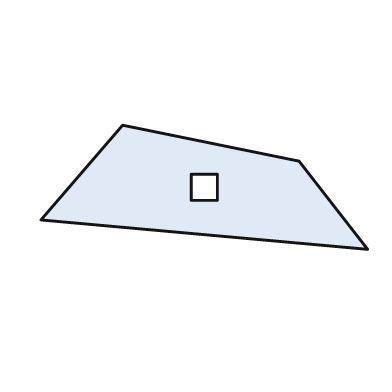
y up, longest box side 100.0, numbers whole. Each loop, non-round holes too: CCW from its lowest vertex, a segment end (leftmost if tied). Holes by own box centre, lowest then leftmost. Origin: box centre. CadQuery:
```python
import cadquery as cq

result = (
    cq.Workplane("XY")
    .moveTo(50.0, -19.0)
    .lineTo(29.0, 8.0)
    .lineTo(-25.0, 19.0)
    .lineTo(-50.0, -10.0)
    .close()
    .moveTo(-4.0, -4.0)
    .lineTo(4.0, -4.0)
    .lineTo(4.0, 4.0)
    .lineTo(-4.0, 4.0)
    .close()
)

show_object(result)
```